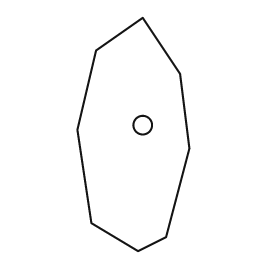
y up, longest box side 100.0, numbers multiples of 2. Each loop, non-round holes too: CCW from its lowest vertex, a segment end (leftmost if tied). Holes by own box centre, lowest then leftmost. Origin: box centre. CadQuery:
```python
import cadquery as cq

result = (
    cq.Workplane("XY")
    .moveTo(2.0, -50.0)
    .lineTo(14.0, -44.0)
    .lineTo(24.0, -6.0)
    .lineTo(20.0, 26.0)
    .lineTo(4.0, 50.0)
    .lineTo(-16.0, 36.0)
    .lineTo(-24.0, 2.0)
    .lineTo(-18.0, -38.0)
    .close()
    .moveTo(4.0, 4.0)
    .circle(4.0)
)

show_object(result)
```